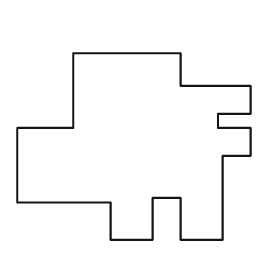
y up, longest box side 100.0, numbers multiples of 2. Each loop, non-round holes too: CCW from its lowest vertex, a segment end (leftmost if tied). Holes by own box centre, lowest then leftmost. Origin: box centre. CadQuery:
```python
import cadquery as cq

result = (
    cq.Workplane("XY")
    .moveTo(-10.0, -40.0)
    .lineTo(8.0, -40.0)
    .lineTo(8.0, -22.0)
    .lineTo(20.0, -22.0)
    .lineTo(20.0, -40.0)
    .lineTo(38.0, -40.0)
    .lineTo(38.0, -4.0)
    .lineTo(50.0, -4.0)
    .lineTo(50.0, 8.0)
    .lineTo(36.0, 8.0)
    .lineTo(36.0, 14.0)
    .lineTo(50.0, 14.0)
    .lineTo(50.0, 26.0)
    .lineTo(20.0, 26.0)
    .lineTo(20.0, 40.0)
    .lineTo(-26.0, 40.0)
    .lineTo(-26.0, 8.0)
    .lineTo(-50.0, 8.0)
    .lineTo(-50.0, -24.0)
    .lineTo(-10.0, -24.0)
    .close()
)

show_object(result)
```